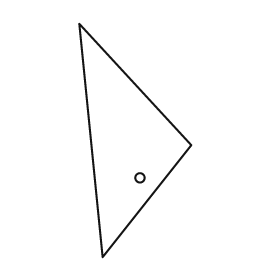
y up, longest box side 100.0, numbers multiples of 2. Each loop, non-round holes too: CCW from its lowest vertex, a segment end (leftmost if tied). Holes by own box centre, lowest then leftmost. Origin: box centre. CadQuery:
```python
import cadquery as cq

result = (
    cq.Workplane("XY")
    .moveTo(-14.0, -50.0)
    .lineTo(24.0, -2.0)
    .lineTo(-24.0, 50.0)
    .close()
    .moveTo(2.0, -16.0)
    .circle(2.0)
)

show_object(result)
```